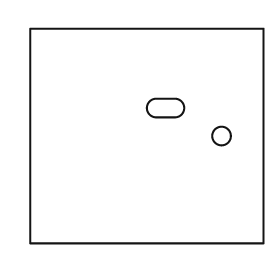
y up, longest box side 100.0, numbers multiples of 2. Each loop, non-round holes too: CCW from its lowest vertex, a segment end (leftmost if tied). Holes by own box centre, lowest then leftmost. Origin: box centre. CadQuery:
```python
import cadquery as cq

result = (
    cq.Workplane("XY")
    .moveTo(-50.0, -46.0)
    .lineTo(50.0, -46.0)
    .lineTo(50.0, 46.0)
    .lineTo(-50.0, 46.0)
    .close()
    .moveTo(32.0, 0.0)
    .circle(4.0)
    .moveTo(4.0, 8.0)
    .lineTo(12.0, 8.0)
    .threePointArc((16.0, 12.0), (12.0, 16.0))
    .lineTo(4.0, 16.0)
    .threePointArc((0.0, 12.0), (4.0, 8.0))
    .close()
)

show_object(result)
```